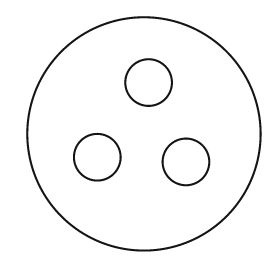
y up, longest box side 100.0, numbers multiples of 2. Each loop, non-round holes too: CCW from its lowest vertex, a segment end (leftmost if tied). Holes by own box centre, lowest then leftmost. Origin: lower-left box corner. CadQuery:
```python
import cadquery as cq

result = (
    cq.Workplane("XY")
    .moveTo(50.0, 50.0)
    .circle(50.0)
    .moveTo(68.0, 38.0)
    .circle(10.0)
    .moveTo(30.0, 40.0)
    .circle(10.0)
    .moveTo(52.0, 72.0)
    .circle(10.0)
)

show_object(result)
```